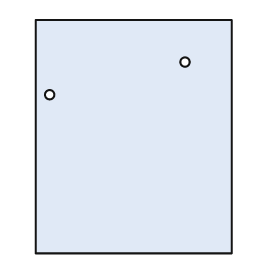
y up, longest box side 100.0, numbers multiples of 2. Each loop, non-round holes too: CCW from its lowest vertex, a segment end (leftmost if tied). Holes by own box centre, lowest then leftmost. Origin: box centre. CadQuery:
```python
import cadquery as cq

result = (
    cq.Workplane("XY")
    .moveTo(-42.0, -50.0)
    .lineTo(42.0, -50.0)
    .lineTo(42.0, 50.0)
    .lineTo(-42.0, 50.0)
    .close()
    .moveTo(-36.0, 18.0)
    .circle(2.0)
    .moveTo(22.0, 32.0)
    .circle(2.0)
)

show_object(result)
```